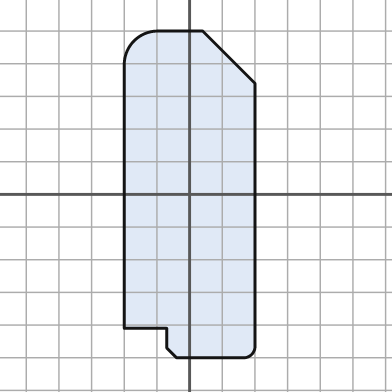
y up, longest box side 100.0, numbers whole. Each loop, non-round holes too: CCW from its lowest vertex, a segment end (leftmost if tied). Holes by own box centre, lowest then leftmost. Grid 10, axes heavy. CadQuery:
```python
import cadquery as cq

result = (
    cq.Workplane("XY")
    .moveTo(-4.0, -50.0)
    .lineTo(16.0, -50.0)
    .threePointArc((19.0, -49.0), (20.0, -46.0))
    .lineTo(20.0, 34.0)
    .lineTo(4.0, 50.0)
    .lineTo(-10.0, 50.0)
    .threePointArc((-17.0, 47.0), (-20.0, 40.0))
    .lineTo(-20.0, -41.0)
    .lineTo(-7.0, -41.0)
    .lineTo(-7.0, -47.0)
    .close()
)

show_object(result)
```